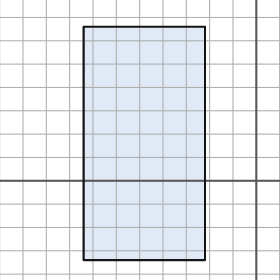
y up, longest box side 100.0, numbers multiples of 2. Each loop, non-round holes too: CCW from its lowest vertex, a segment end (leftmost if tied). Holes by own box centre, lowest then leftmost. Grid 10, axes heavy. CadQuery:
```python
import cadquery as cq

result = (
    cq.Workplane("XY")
    .moveTo(-74.0, -34.0)
    .lineTo(-22.0, -34.0)
    .lineTo(-22.0, 66.0)
    .lineTo(-74.0, 66.0)
    .close()
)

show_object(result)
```